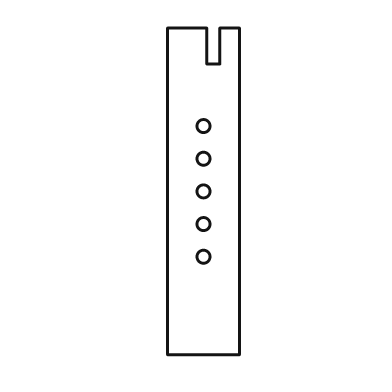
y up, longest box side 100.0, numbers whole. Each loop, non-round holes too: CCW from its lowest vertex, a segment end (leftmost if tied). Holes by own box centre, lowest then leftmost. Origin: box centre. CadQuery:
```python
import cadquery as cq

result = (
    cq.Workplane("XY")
    .moveTo(-11.0, -50.0)
    .lineTo(11.0, -50.0)
    .lineTo(11.0, 50.0)
    .lineTo(5.0, 50.0)
    .lineTo(5.0, 39.0)
    .lineTo(1.0, 39.0)
    .lineTo(1.0, 50.0)
    .lineTo(-11.0, 50.0)
    .close()
    .moveTo(0.0, -20.0)
    .circle(2.0)
    .moveTo(0.0, -10.0)
    .circle(2.0)
    .moveTo(0.0, 0.0)
    .circle(2.0)
    .moveTo(0.0, 10.0)
    .circle(2.0)
    .moveTo(0.0, 20.0)
    .circle(2.0)
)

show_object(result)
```